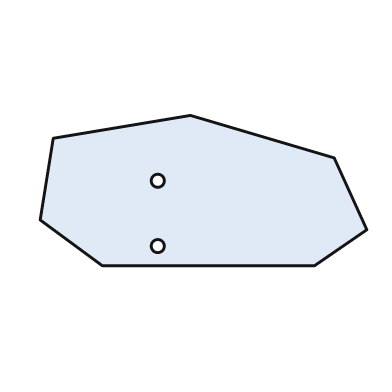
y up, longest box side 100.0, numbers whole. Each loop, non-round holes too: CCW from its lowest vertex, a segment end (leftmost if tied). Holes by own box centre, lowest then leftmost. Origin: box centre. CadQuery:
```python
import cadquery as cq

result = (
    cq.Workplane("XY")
    .moveTo(-31.0, -23.0)
    .lineTo(34.0, -23.0)
    .lineTo(50.0, -12.0)
    .lineTo(40.0, 10.0)
    .lineTo(-4.0, 23.0)
    .lineTo(-46.0, 16.0)
    .lineTo(-50.0, -9.0)
    .close()
    .moveTo(-14.0, -17.0)
    .circle(2.0)
    .moveTo(-14.0, 3.0)
    .circle(2.0)
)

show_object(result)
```